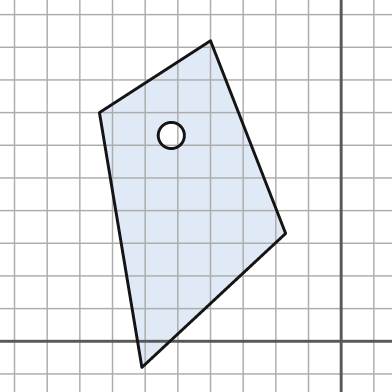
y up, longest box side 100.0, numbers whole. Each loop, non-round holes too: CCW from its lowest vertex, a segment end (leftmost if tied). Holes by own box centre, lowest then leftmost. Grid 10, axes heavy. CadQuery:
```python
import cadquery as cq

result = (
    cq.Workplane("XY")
    .moveTo(-61.0, -8.0)
    .lineTo(-17.0, 33.0)
    .lineTo(-40.0, 92.0)
    .lineTo(-74.0, 70.0)
    .close()
    .moveTo(-52.0, 63.0)
    .circle(4.0)
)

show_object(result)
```